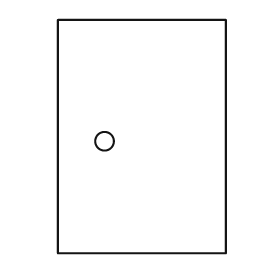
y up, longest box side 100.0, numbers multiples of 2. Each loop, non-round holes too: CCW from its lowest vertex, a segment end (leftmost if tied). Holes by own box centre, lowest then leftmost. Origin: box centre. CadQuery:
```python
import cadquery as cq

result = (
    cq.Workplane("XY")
    .moveTo(-36.0, -50.0)
    .lineTo(36.0, -50.0)
    .lineTo(36.0, 50.0)
    .lineTo(-36.0, 50.0)
    .close()
    .moveTo(-16.0, -2.0)
    .circle(4.0)
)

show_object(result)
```